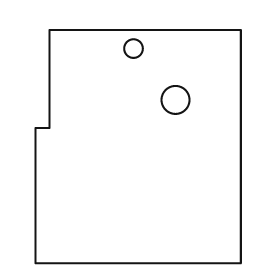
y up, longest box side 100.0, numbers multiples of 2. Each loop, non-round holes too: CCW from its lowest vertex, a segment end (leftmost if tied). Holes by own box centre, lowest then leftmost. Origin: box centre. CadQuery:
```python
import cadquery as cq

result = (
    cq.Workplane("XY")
    .moveTo(-44.0, -50.0)
    .lineTo(44.0, -50.0)
    .lineTo(44.0, 50.0)
    .lineTo(-38.0, 50.0)
    .lineTo(-38.0, 8.0)
    .lineTo(-44.0, 8.0)
    .close()
    .moveTo(16.0, 20.0)
    .circle(6.0)
    .moveTo(-2.0, 42.0)
    .circle(4.0)
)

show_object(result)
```